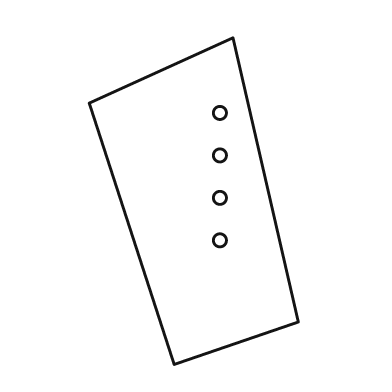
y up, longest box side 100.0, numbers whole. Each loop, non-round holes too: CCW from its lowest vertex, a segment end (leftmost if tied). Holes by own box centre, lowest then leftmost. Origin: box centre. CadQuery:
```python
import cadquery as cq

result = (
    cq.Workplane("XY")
    .moveTo(-6.0, -50.0)
    .lineTo(32.0, -37.0)
    .lineTo(12.0, 50.0)
    .lineTo(-32.0, 30.0)
    .close()
    .moveTo(8.0, -12.0)
    .circle(2.0)
    .moveTo(8.0, 1.0)
    .circle(2.0)
    .moveTo(8.0, 14.0)
    .circle(2.0)
    .moveTo(8.0, 27.0)
    .circle(2.0)
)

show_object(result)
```